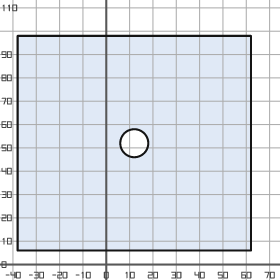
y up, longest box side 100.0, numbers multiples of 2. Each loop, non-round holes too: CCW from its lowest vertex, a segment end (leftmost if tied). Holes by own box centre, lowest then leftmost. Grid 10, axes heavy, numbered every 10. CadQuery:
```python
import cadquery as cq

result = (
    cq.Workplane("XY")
    .moveTo(-38.0, 6.0)
    .lineTo(62.0, 6.0)
    .lineTo(62.0, 98.0)
    .lineTo(-38.0, 98.0)
    .close()
    .moveTo(12.0, 52.0)
    .circle(6.0)
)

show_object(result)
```